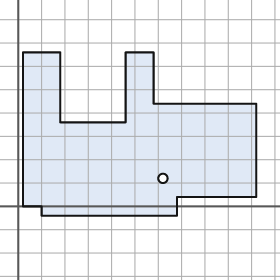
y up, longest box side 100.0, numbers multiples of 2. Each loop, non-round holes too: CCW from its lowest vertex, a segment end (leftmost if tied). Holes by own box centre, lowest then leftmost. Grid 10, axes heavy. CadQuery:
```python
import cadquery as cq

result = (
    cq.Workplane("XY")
    .moveTo(10.0, -4.0)
    .lineTo(68.0, -4.0)
    .lineTo(68.0, 4.0)
    .lineTo(102.0, 4.0)
    .lineTo(102.0, 44.0)
    .lineTo(58.0, 44.0)
    .lineTo(58.0, 66.0)
    .lineTo(46.0, 66.0)
    .lineTo(46.0, 36.0)
    .lineTo(18.0, 36.0)
    .lineTo(18.0, 66.0)
    .lineTo(2.0, 66.0)
    .lineTo(2.0, 0.0)
    .lineTo(10.0, 0.0)
    .close()
    .moveTo(62.0, 12.0)
    .circle(2.0)
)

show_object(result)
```